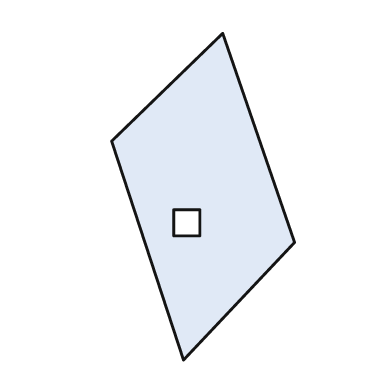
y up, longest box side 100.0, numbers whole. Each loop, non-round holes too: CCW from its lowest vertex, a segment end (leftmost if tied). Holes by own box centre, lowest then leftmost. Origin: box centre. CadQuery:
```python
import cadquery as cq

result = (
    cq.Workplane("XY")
    .moveTo(-6.0, -50.0)
    .lineTo(28.0, -14.0)
    .lineTo(6.0, 50.0)
    .lineTo(-28.0, 17.0)
    .close()
    .moveTo(-9.0, -12.0)
    .lineTo(-1.0, -12.0)
    .lineTo(-1.0, -4.0)
    .lineTo(-9.0, -4.0)
    .close()
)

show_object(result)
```